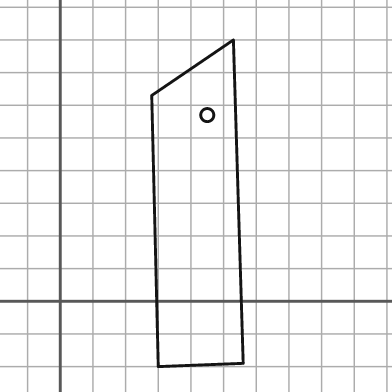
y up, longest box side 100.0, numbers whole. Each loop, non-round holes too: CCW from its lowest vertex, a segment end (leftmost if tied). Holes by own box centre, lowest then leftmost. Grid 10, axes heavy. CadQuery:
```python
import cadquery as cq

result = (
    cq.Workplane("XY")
    .moveTo(30.0, -20.0)
    .lineTo(56.0, -19.0)
    .lineTo(53.0, 80.0)
    .lineTo(28.0, 63.0)
    .close()
    .moveTo(45.0, 57.0)
    .circle(2.0)
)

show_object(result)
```